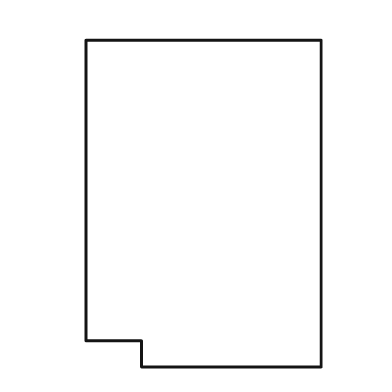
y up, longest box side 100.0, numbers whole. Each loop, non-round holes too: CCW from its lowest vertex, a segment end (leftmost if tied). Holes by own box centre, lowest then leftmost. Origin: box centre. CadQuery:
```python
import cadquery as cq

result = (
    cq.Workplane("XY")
    .moveTo(-19.0, -50.0)
    .lineTo(36.0, -50.0)
    .lineTo(36.0, 50.0)
    .lineTo(-36.0, 50.0)
    .lineTo(-36.0, -42.0)
    .lineTo(-19.0, -42.0)
    .close()
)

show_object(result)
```